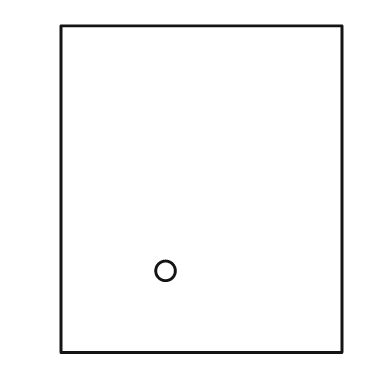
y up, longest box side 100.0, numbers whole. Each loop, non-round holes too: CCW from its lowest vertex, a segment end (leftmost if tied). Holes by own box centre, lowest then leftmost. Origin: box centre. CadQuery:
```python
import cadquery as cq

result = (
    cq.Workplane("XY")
    .moveTo(-43.0, -50.0)
    .lineTo(43.0, -50.0)
    .lineTo(43.0, 50.0)
    .lineTo(-43.0, 50.0)
    .close()
    .moveTo(-11.0, -25.0)
    .circle(3.0)
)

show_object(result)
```